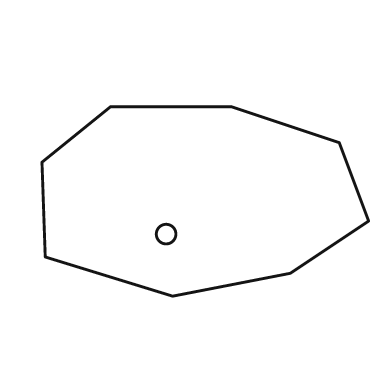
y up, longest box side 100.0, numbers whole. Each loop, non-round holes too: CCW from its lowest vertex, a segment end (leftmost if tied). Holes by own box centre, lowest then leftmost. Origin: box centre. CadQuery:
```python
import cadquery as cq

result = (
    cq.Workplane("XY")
    .moveTo(-10.0, -29.0)
    .lineTo(26.0, -22.0)
    .lineTo(50.0, -6.0)
    .lineTo(41.0, 18.0)
    .lineTo(8.0, 29.0)
    .lineTo(-29.0, 29.0)
    .lineTo(-50.0, 12.0)
    .lineTo(-49.0, -17.0)
    .close()
    .moveTo(-12.0, -10.0)
    .circle(3.0)
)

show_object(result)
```